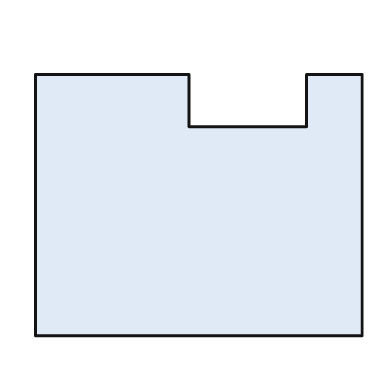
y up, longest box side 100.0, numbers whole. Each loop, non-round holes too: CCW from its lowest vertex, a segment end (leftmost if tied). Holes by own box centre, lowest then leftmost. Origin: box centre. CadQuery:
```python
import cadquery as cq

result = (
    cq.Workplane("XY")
    .moveTo(-50.0, -40.0)
    .lineTo(50.0, -40.0)
    .lineTo(50.0, 40.0)
    .lineTo(33.0, 40.0)
    .lineTo(33.0, 24.0)
    .lineTo(-3.0, 24.0)
    .lineTo(-3.0, 40.0)
    .lineTo(-50.0, 40.0)
    .close()
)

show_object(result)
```